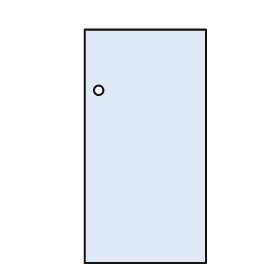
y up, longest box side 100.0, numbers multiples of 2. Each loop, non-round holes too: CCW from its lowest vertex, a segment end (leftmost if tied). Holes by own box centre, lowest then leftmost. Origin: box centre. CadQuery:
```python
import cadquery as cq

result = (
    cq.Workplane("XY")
    .moveTo(-26.0, -50.0)
    .lineTo(26.0, -50.0)
    .lineTo(26.0, 50.0)
    .lineTo(-26.0, 50.0)
    .close()
    .moveTo(-20.0, 24.0)
    .circle(2.0)
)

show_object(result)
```